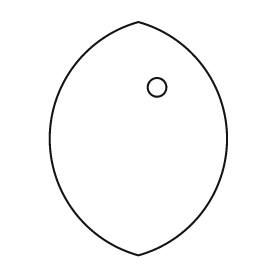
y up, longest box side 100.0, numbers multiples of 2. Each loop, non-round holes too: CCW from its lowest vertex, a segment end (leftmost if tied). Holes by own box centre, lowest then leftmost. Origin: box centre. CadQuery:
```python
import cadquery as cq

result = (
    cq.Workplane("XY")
    .moveTo(0.0, -50.0)
    .threePointArc((38.0, 0.0), (0.0, 50.0))
    .threePointArc((-38.0, 0.0), (0.0, -50.0))
    .close()
    .moveTo(8.0, 22.0)
    .circle(4.0)
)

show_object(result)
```